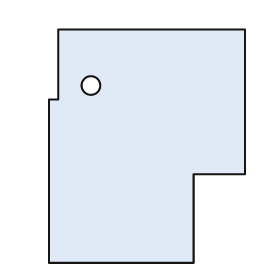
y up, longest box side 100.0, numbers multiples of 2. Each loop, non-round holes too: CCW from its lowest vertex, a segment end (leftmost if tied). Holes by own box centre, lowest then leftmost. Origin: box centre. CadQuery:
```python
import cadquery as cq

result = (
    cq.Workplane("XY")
    .moveTo(-42.0, -50.0)
    .lineTo(20.0, -50.0)
    .lineTo(20.0, -12.0)
    .lineTo(42.0, -12.0)
    .lineTo(42.0, 50.0)
    .lineTo(-38.0, 50.0)
    .lineTo(-38.0, 20.0)
    .lineTo(-42.0, 20.0)
    .close()
    .moveTo(-24.0, 26.0)
    .circle(4.0)
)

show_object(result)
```